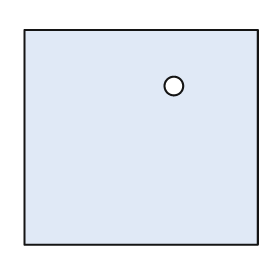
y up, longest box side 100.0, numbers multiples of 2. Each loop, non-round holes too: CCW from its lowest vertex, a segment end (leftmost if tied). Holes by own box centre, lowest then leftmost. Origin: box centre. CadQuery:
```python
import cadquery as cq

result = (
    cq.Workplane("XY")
    .moveTo(-50.0, -46.0)
    .lineTo(50.0, -46.0)
    .lineTo(50.0, 46.0)
    .lineTo(-50.0, 46.0)
    .close()
    .moveTo(14.0, 22.0)
    .circle(4.0)
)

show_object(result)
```